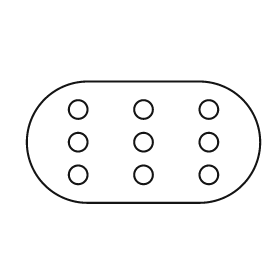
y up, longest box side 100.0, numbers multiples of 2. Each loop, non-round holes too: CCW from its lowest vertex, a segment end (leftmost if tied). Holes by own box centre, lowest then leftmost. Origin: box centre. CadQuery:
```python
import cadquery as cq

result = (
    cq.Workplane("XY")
    .moveTo(-24.0, -26.0)
    .lineTo(24.0, -26.0)
    .threePointArc((50.0, 0.0), (24.0, 26.0))
    .lineTo(-24.0, 26.0)
    .threePointArc((-50.0, 0.0), (-24.0, -26.0))
    .close()
    .moveTo(-28.0, -14.0)
    .circle(4.0)
    .moveTo(0.0, -14.0)
    .circle(4.0)
    .moveTo(28.0, -14.0)
    .circle(4.0)
    .moveTo(-28.0, 0.0)
    .circle(4.0)
    .moveTo(0.0, 0.0)
    .circle(4.0)
    .moveTo(28.0, 0.0)
    .circle(4.0)
    .moveTo(-28.0, 14.0)
    .circle(4.0)
    .moveTo(0.0, 14.0)
    .circle(4.0)
    .moveTo(28.0, 14.0)
    .circle(4.0)
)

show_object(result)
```